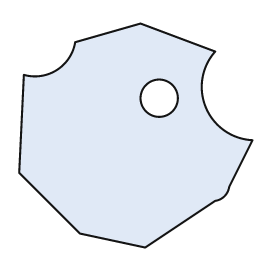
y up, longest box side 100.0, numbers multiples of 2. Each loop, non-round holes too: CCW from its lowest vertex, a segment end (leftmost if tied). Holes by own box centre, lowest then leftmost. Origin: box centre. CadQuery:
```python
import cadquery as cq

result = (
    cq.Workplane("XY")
    .moveTo(4.0, -48.0)
    .lineTo(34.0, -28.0)
    .threePointArc((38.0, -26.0), (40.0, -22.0))
    .lineTo(50.0, -2.0)
    .threePointArc((30.0, 12.0), (34.0, 36.0))
    .lineTo(2.0, 48.0)
    .lineTo(-26.0, 40.0)
    .threePointArc((-34.0, 28.0), (-48.0, 26.0))
    .lineTo(-50.0, -16.0)
    .lineTo(-24.0, -42.0)
    .close()
    .moveTo(10.0, 16.0)
    .circle(8.0)
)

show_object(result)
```